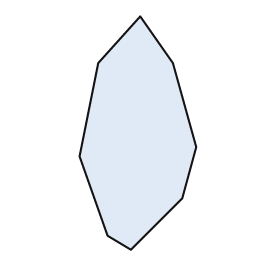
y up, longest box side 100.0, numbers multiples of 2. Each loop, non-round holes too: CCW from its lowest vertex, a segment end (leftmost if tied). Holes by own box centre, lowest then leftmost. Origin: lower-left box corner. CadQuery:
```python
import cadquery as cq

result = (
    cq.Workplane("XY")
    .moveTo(22.0, 0.0)
    .lineTo(44.0, 22.0)
    .lineTo(50.0, 44.0)
    .lineTo(40.0, 80.0)
    .lineTo(26.0, 100.0)
    .lineTo(8.0, 80.0)
    .lineTo(0.0, 40.0)
    .lineTo(12.0, 6.0)
    .close()
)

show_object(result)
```